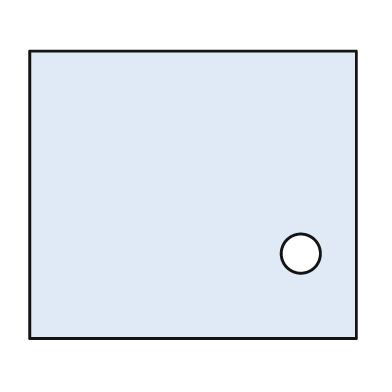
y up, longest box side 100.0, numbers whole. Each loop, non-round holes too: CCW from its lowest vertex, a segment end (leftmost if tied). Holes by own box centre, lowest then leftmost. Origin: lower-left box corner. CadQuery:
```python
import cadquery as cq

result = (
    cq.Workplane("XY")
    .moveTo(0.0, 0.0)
    .lineTo(100.0, 0.0)
    .lineTo(100.0, 88.0)
    .lineTo(0.0, 88.0)
    .close()
    .moveTo(83.0, 26.0)
    .circle(6.0)
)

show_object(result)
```